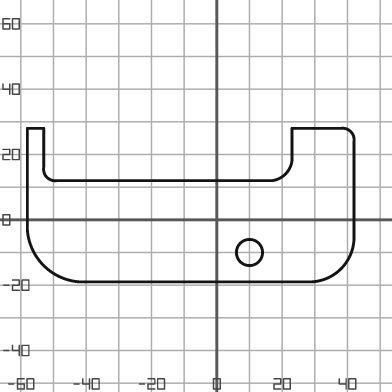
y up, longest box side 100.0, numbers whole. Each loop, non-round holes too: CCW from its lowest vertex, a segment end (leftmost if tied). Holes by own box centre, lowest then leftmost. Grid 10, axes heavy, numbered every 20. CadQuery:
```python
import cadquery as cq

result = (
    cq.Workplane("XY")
    .moveTo(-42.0, -19.0)
    .lineTo(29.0, -19.0)
    .threePointArc((38.0, -15.0), (42.0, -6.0))
    .lineTo(42.0, 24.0)
    .threePointArc((41.0, 27.0), (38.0, 28.0))
    .lineTo(23.0, 28.0)
    .lineTo(23.0, 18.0)
    .threePointArc((21.0, 14.0), (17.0, 12.0))
    .lineTo(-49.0, 12.0)
    .threePointArc((-52.0, 13.0), (-53.0, 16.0))
    .lineTo(-53.0, 28.0)
    .lineTo(-58.0, 28.0)
    .lineTo(-58.0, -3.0)
    .threePointArc((-53.0, -14.0), (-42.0, -19.0))
    .close()
    .moveTo(10.0, -10.0)
    .circle(4.0)
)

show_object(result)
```